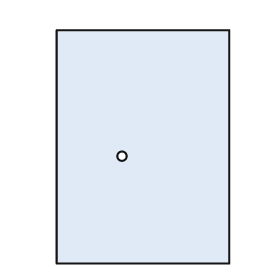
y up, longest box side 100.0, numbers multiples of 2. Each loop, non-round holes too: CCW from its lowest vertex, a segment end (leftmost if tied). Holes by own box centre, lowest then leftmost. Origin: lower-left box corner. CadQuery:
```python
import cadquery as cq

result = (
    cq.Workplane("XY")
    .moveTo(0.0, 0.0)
    .lineTo(74.0, 0.0)
    .lineTo(74.0, 100.0)
    .lineTo(0.0, 100.0)
    .close()
    .moveTo(28.0, 46.0)
    .circle(2.0)
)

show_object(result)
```